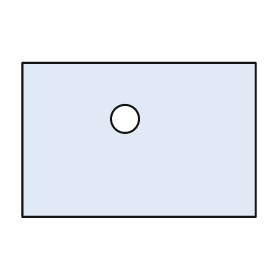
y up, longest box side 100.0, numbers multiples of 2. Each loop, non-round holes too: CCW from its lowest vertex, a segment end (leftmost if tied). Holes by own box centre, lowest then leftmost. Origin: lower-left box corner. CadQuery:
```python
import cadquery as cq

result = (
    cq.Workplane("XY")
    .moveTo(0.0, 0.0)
    .lineTo(100.0, 0.0)
    .lineTo(100.0, 66.0)
    .lineTo(0.0, 66.0)
    .close()
    .moveTo(44.0, 42.0)
    .circle(6.0)
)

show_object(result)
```